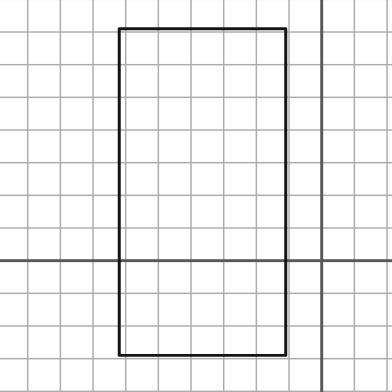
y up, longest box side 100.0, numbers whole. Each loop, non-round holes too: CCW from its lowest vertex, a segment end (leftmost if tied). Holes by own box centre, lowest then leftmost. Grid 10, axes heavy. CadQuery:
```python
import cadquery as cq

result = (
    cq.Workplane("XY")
    .moveTo(-62.0, -29.0)
    .lineTo(-11.0, -29.0)
    .lineTo(-11.0, 71.0)
    .lineTo(-62.0, 71.0)
    .close()
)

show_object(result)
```